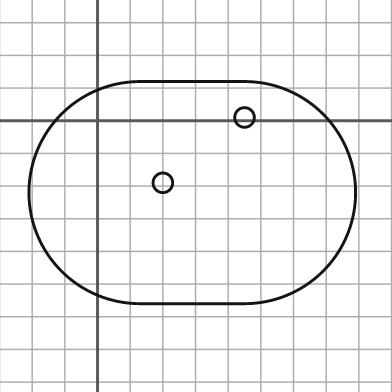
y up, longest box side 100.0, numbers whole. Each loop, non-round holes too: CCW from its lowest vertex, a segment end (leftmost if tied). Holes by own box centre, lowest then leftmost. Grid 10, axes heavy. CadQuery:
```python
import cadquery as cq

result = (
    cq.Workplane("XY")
    .moveTo(13.0, -56.0)
    .lineTo(45.0, -56.0)
    .threePointArc((79.0, -22.0), (45.0, 12.0))
    .lineTo(13.0, 12.0)
    .threePointArc((-21.0, -22.0), (13.0, -56.0))
    .close()
    .moveTo(20.0, -19.0)
    .circle(3.0)
    .moveTo(45.0, 1.0)
    .circle(3.0)
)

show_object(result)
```